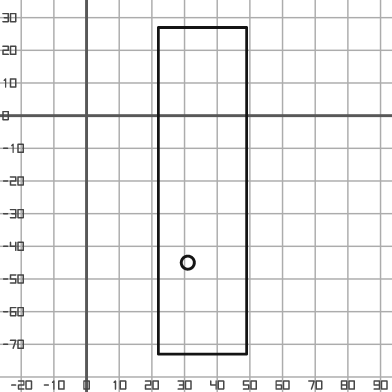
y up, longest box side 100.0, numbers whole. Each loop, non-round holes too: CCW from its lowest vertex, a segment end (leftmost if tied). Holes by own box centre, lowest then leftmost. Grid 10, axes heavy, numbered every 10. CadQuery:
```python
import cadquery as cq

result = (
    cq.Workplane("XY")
    .moveTo(22.0, -73.0)
    .lineTo(49.0, -73.0)
    .lineTo(49.0, 27.0)
    .lineTo(22.0, 27.0)
    .close()
    .moveTo(31.0, -45.0)
    .circle(2.0)
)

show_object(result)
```